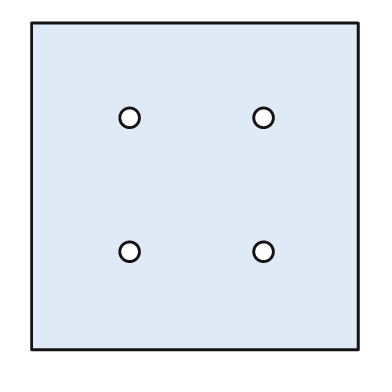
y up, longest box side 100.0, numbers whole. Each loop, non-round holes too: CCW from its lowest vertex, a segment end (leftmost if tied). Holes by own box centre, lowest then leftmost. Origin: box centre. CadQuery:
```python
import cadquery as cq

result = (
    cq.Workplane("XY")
    .moveTo(-50.0, -50.0)
    .lineTo(50.0, -50.0)
    .lineTo(50.0, 50.0)
    .lineTo(-50.0, 50.0)
    .close()
    .moveTo(-20.0, -20.0)
    .circle(3.0)
    .moveTo(21.0, -20.0)
    .circle(3.0)
    .moveTo(-20.0, 21.0)
    .circle(3.0)
    .moveTo(21.0, 21.0)
    .circle(3.0)
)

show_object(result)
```